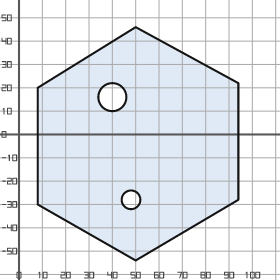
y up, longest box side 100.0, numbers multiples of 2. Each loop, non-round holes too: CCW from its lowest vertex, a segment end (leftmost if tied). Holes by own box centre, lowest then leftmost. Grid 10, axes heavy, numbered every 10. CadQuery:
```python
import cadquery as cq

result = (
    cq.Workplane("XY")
    .moveTo(50.0, -54.0)
    .lineTo(94.0, -28.0)
    .lineTo(94.0, 22.0)
    .lineTo(50.0, 46.0)
    .lineTo(8.0, 20.0)
    .lineTo(8.0, -30.0)
    .close()
    .moveTo(48.0, -28.0)
    .circle(4.0)
    .moveTo(40.0, 16.0)
    .circle(6.0)
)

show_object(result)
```